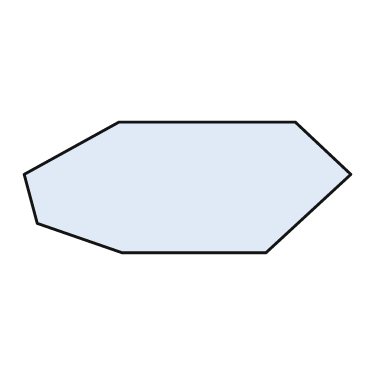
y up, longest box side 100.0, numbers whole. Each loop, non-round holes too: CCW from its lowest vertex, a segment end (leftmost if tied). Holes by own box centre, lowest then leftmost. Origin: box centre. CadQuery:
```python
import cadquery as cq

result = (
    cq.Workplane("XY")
    .moveTo(-20.0, -20.0)
    .lineTo(24.0, -20.0)
    .lineTo(50.0, 4.0)
    .lineTo(33.0, 20.0)
    .lineTo(-21.0, 20.0)
    .lineTo(-50.0, 4.0)
    .lineTo(-46.0, -11.0)
    .close()
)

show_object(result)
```